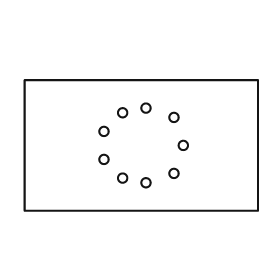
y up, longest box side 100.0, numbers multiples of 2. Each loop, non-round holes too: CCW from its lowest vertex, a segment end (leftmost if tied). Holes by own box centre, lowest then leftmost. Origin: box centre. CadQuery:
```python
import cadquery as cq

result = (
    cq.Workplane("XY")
    .moveTo(-50.0, -28.0)
    .lineTo(50.0, -28.0)
    .lineTo(50.0, 28.0)
    .lineTo(-50.0, 28.0)
    .close()
    .moveTo(2.0, -16.0)
    .circle(2.0)
    .moveTo(-8.0, -14.0)
    .circle(2.0)
    .moveTo(14.0, -12.0)
    .circle(2.0)
    .moveTo(-16.0, -6.0)
    .circle(2.0)
    .moveTo(18.0, 0.0)
    .circle(2.0)
    .moveTo(-16.0, 6.0)
    .circle(2.0)
    .moveTo(14.0, 12.0)
    .circle(2.0)
    .moveTo(-8.0, 14.0)
    .circle(2.0)
    .moveTo(2.0, 16.0)
    .circle(2.0)
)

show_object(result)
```